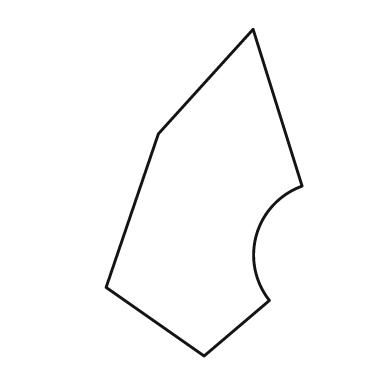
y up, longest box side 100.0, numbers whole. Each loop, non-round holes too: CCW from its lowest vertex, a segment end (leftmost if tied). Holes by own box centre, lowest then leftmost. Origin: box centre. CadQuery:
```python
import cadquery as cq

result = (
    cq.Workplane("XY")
    .moveTo(0.0, -50.0)
    .lineTo(20.0, -33.0)
    .threePointArc((16.0, -13.0), (30.0, 2.0))
    .lineTo(15.0, 50.0)
    .lineTo(-14.0, 18.0)
    .lineTo(-30.0, -29.0)
    .close()
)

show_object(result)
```